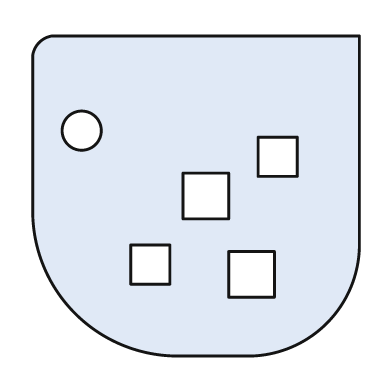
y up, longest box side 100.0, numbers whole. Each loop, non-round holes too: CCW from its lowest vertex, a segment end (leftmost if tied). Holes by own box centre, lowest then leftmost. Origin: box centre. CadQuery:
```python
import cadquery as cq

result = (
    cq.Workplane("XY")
    .moveTo(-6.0, -49.0)
    .lineTo(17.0, -49.0)
    .threePointArc((40.0, -39.0), (50.0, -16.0))
    .lineTo(50.0, 49.0)
    .lineTo(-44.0, 49.0)
    .threePointArc((-48.0, 47.0), (-50.0, 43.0))
    .lineTo(-50.0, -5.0)
    .threePointArc((-37.0, -36.0), (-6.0, -49.0))
    .close()
    .moveTo(10.0, -31.0)
    .lineTo(24.0, -31.0)
    .lineTo(24.0, -17.0)
    .lineTo(10.0, -17.0)
    .close()
    .moveTo(-20.0, -27.0)
    .lineTo(-8.0, -27.0)
    .lineTo(-8.0, -15.0)
    .lineTo(-20.0, -15.0)
    .close()
    .moveTo(-4.0, -7.0)
    .lineTo(10.0, -7.0)
    .lineTo(10.0, 7.0)
    .lineTo(-4.0, 7.0)
    .close()
    .moveTo(19.0, 6.0)
    .lineTo(31.0, 6.0)
    .lineTo(31.0, 18.0)
    .lineTo(19.0, 18.0)
    .close()
    .moveTo(-35.0, 20.0)
    .circle(6.0)
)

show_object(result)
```